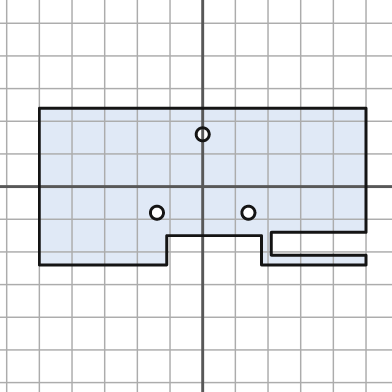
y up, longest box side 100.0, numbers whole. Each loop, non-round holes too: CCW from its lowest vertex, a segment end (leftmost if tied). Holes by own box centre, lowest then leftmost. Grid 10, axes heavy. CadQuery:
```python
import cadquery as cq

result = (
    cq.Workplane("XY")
    .moveTo(-50.0, -24.0)
    .lineTo(-11.0, -24.0)
    .lineTo(-11.0, -15.0)
    .lineTo(18.0, -15.0)
    .lineTo(18.0, -24.0)
    .lineTo(50.0, -24.0)
    .lineTo(50.0, -21.0)
    .lineTo(21.0, -21.0)
    .lineTo(21.0, -14.0)
    .lineTo(50.0, -14.0)
    .lineTo(50.0, 24.0)
    .lineTo(-50.0, 24.0)
    .close()
    .moveTo(-14.0, -8.0)
    .circle(2.0)
    .moveTo(14.0, -8.0)
    .circle(2.0)
    .moveTo(0.0, 16.0)
    .circle(2.0)
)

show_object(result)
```